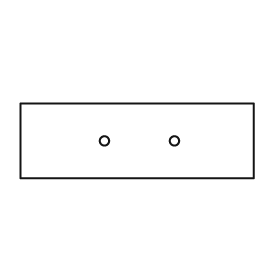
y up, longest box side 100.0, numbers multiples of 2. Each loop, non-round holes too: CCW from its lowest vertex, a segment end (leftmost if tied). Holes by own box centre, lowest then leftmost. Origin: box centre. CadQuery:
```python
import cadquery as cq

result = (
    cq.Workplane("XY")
    .moveTo(-50.0, -16.0)
    .lineTo(50.0, -16.0)
    .lineTo(50.0, 16.0)
    .lineTo(-50.0, 16.0)
    .close()
    .moveTo(-14.0, 0.0)
    .circle(2.0)
    .moveTo(16.0, 0.0)
    .circle(2.0)
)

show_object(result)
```